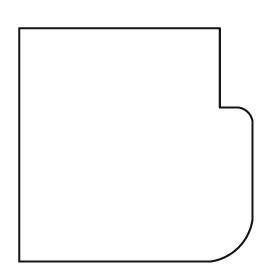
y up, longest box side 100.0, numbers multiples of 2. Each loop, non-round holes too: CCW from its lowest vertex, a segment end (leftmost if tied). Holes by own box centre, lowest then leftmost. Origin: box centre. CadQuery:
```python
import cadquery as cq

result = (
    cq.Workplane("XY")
    .moveTo(-50.0, -50.0)
    .lineTo(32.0, -50.0)
    .threePointArc((44.0, -44.0), (50.0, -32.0))
    .lineTo(50.0, 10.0)
    .threePointArc((48.0, 14.0), (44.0, 16.0))
    .lineTo(36.0, 16.0)
    .lineTo(36.0, 50.0)
    .lineTo(-50.0, 50.0)
    .close()
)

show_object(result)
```